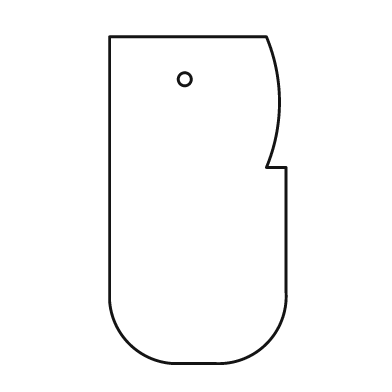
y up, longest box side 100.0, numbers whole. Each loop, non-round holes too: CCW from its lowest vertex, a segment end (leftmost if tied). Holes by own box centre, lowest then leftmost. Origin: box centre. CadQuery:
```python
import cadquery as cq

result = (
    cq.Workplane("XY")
    .moveTo(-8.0, -50.0)
    .lineTo(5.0, -50.0)
    .threePointArc((21.0, -44.0), (27.0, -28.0))
    .lineTo(27.0, 10.0)
    .lineTo(21.0, 10.0)
    .threePointArc((25.0, 30.0), (21.0, 50.0))
    .lineTo(-27.0, 50.0)
    .lineTo(-27.0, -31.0)
    .threePointArc((-21.0, -44.0), (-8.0, -50.0))
    .close()
    .moveTo(-4.0, 37.0)
    .circle(2.0)
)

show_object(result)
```